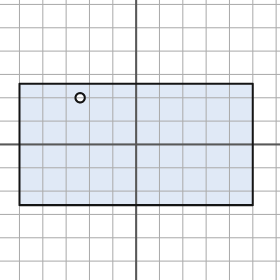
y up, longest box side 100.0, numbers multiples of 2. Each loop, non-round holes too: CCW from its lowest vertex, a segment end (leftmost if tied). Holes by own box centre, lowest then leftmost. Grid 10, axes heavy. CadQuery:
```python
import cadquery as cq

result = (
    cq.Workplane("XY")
    .moveTo(-50.0, -26.0)
    .lineTo(50.0, -26.0)
    .lineTo(50.0, 26.0)
    .lineTo(-50.0, 26.0)
    .close()
    .moveTo(-24.0, 20.0)
    .circle(2.0)
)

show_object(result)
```